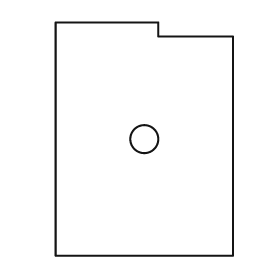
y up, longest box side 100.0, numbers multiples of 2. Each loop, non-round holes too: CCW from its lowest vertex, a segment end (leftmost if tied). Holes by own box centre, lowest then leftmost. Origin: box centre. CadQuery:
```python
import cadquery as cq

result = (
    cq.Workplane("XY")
    .moveTo(-38.0, -50.0)
    .lineTo(38.0, -50.0)
    .lineTo(38.0, 44.0)
    .lineTo(6.0, 44.0)
    .lineTo(6.0, 50.0)
    .lineTo(-38.0, 50.0)
    .close()
    .moveTo(0.0, 0.0)
    .circle(6.0)
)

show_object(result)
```